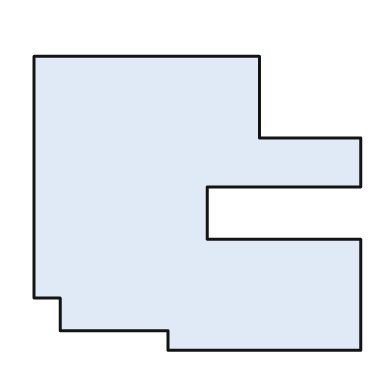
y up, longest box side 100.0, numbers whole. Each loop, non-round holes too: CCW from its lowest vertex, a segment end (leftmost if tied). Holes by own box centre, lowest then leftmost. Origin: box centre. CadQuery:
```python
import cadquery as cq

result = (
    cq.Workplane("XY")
    .moveTo(-9.0, -45.0)
    .lineTo(50.0, -45.0)
    .lineTo(50.0, -11.0)
    .lineTo(3.0, -11.0)
    .lineTo(3.0, 5.0)
    .lineTo(50.0, 5.0)
    .lineTo(50.0, 20.0)
    .lineTo(19.0, 20.0)
    .lineTo(19.0, 45.0)
    .lineTo(-50.0, 45.0)
    .lineTo(-50.0, -29.0)
    .lineTo(-42.0, -29.0)
    .lineTo(-42.0, -39.0)
    .lineTo(-9.0, -39.0)
    .close()
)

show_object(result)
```